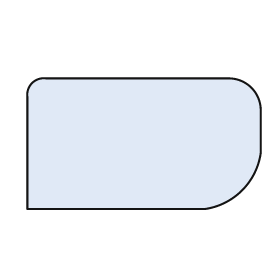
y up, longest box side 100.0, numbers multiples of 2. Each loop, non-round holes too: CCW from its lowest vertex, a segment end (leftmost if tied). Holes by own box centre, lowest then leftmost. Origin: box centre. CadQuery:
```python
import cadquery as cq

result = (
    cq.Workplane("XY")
    .moveTo(-50.0, -28.0)
    .lineTo(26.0, -28.0)
    .threePointArc((42.0, -20.0), (50.0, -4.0))
    .lineTo(50.0, 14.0)
    .threePointArc((46.0, 24.0), (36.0, 28.0))
    .lineTo(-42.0, 28.0)
    .threePointArc((-48.0, 26.0), (-50.0, 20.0))
    .close()
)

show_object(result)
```